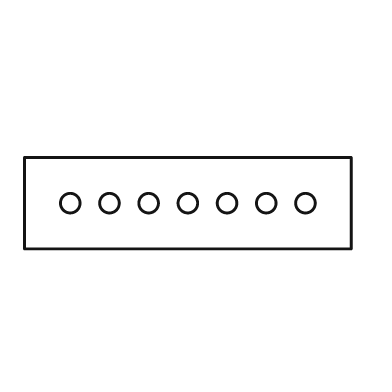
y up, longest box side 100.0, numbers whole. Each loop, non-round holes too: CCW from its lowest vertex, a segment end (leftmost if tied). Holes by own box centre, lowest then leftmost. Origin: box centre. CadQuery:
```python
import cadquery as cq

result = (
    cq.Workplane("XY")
    .moveTo(-50.0, -14.0)
    .lineTo(50.0, -14.0)
    .lineTo(50.0, 14.0)
    .lineTo(-50.0, 14.0)
    .close()
    .moveTo(-36.0, 0.0)
    .circle(3.0)
    .moveTo(-24.0, 0.0)
    .circle(3.0)
    .moveTo(-12.0, 0.0)
    .circle(3.0)
    .moveTo(0.0, 0.0)
    .circle(3.0)
    .moveTo(12.0, 0.0)
    .circle(3.0)
    .moveTo(24.0, 0.0)
    .circle(3.0)
    .moveTo(36.0, 0.0)
    .circle(3.0)
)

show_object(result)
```